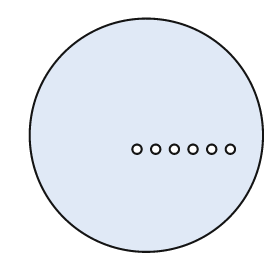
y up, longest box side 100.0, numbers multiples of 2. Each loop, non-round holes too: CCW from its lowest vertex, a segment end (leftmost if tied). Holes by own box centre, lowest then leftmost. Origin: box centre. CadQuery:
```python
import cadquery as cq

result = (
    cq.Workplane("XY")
    .moveTo(0.0, 0.0)
    .circle(50.0)
    .moveTo(-4.0, -6.0)
    .circle(2.0)
    .moveTo(4.0, -6.0)
    .circle(2.0)
    .moveTo(12.0, -6.0)
    .circle(2.0)
    .moveTo(20.0, -6.0)
    .circle(2.0)
    .moveTo(28.0, -6.0)
    .circle(2.0)
    .moveTo(36.0, -6.0)
    .circle(2.0)
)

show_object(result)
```